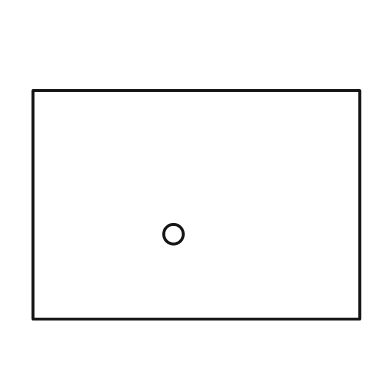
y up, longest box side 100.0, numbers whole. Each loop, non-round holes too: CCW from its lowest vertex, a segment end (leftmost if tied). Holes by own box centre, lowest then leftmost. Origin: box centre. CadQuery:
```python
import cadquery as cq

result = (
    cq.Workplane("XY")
    .moveTo(-50.0, -35.0)
    .lineTo(50.0, -35.0)
    .lineTo(50.0, 35.0)
    .lineTo(-50.0, 35.0)
    .close()
    .moveTo(-7.0, -9.0)
    .circle(3.0)
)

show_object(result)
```